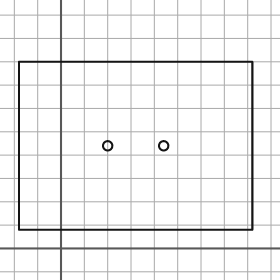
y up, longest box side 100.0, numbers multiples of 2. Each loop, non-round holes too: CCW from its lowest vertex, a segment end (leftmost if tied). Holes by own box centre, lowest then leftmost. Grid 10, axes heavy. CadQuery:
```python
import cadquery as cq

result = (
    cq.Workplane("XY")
    .moveTo(-18.0, 8.0)
    .lineTo(82.0, 8.0)
    .lineTo(82.0, 80.0)
    .lineTo(-18.0, 80.0)
    .close()
    .moveTo(20.0, 44.0)
    .circle(2.0)
    .moveTo(44.0, 44.0)
    .circle(2.0)
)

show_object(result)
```